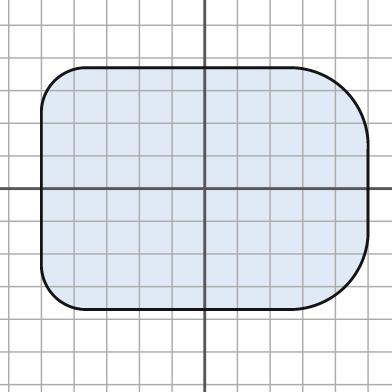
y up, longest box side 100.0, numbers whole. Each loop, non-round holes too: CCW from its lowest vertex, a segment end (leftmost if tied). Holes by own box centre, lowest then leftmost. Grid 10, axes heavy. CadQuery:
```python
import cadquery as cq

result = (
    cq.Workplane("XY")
    .moveTo(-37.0, -37.0)
    .lineTo(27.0, -37.0)
    .threePointArc((43.0, -30.0), (50.0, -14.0))
    .lineTo(50.0, 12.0)
    .threePointArc((43.0, 30.0), (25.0, 37.0))
    .lineTo(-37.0, 37.0)
    .threePointArc((-46.0, 33.0), (-50.0, 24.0))
    .lineTo(-50.0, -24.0)
    .threePointArc((-46.0, -33.0), (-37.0, -37.0))
    .close()
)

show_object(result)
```